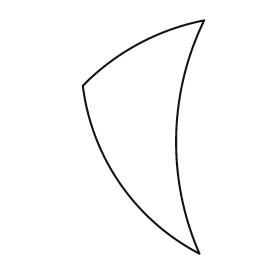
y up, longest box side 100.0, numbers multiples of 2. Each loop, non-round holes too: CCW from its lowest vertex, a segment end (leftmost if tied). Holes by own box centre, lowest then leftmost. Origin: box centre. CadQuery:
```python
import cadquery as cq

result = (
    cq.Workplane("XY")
    .moveTo(24.0, -50.0)
    .threePointArc((14.0, 0.0), (26.0, 50.0))
    .threePointArc((-2.0, 40.0), (-26.0, 22.0))
    .threePointArc((-10.0, -20.0), (24.0, -50.0))
    .close()
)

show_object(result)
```